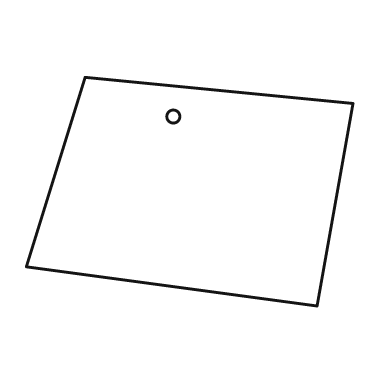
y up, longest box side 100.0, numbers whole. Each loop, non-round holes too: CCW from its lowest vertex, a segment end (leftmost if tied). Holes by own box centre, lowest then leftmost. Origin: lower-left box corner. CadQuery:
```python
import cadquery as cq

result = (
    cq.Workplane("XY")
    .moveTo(89.0, 0.0)
    .lineTo(100.0, 62.0)
    .lineTo(18.0, 70.0)
    .lineTo(0.0, 12.0)
    .close()
    .moveTo(45.0, 58.0)
    .circle(2.0)
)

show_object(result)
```